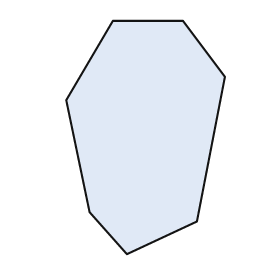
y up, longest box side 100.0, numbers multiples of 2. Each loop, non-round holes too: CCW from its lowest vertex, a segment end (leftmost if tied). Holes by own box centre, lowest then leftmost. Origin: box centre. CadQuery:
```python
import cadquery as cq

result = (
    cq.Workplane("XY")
    .moveTo(-8.0, -50.0)
    .lineTo(22.0, -36.0)
    .lineTo(34.0, 26.0)
    .lineTo(16.0, 50.0)
    .lineTo(-14.0, 50.0)
    .lineTo(-34.0, 16.0)
    .lineTo(-24.0, -32.0)
    .close()
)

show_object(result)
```